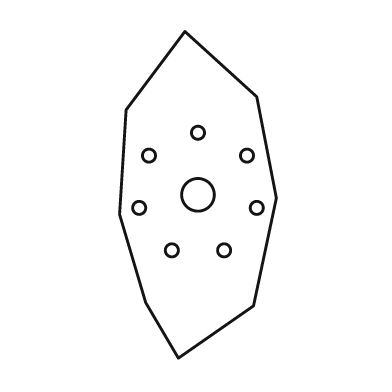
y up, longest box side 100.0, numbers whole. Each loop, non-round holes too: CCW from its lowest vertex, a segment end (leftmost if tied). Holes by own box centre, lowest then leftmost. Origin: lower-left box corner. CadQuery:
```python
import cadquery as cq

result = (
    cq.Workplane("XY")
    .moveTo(18.0, 0.0)
    .lineTo(41.0, 16.0)
    .lineTo(48.0, 49.0)
    .lineTo(42.0, 80.0)
    .lineTo(20.0, 100.0)
    .lineTo(2.0, 76.0)
    .lineTo(0.0, 44.0)
    .lineTo(8.0, 17.0)
    .close()
    .moveTo(16.0, 33.0)
    .circle(2.0)
    .moveTo(32.0, 33.0)
    .circle(2.0)
    .moveTo(6.0, 46.0)
    .circle(2.0)
    .moveTo(42.0, 46.0)
    .circle(2.0)
    .moveTo(24.0, 50.0)
    .circle(5.0)
    .moveTo(9.0, 62.0)
    .circle(2.0)
    .moveTo(39.0, 62.0)
    .circle(2.0)
    .moveTo(24.0, 69.0)
    .circle(2.0)
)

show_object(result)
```